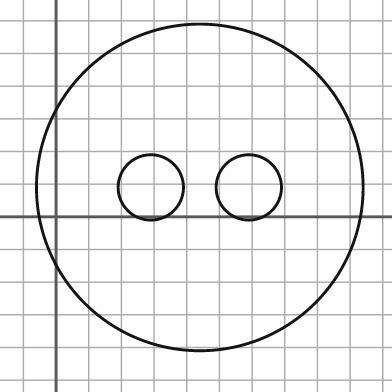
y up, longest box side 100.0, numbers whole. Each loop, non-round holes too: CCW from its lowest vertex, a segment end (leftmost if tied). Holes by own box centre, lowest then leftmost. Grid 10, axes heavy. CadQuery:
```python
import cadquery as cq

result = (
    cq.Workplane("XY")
    .moveTo(44.0, 9.0)
    .circle(50.0)
    .moveTo(29.0, 9.0)
    .circle(10.0)
    .moveTo(59.0, 9.0)
    .circle(10.0)
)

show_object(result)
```